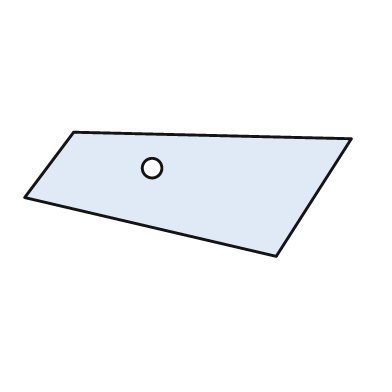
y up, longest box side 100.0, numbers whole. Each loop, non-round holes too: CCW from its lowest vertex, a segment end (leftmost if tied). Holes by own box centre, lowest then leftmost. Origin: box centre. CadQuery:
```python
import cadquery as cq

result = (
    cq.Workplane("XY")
    .moveTo(27.0, -19.0)
    .lineTo(50.0, 17.0)
    .lineTo(-35.0, 19.0)
    .lineTo(-50.0, -1.0)
    .close()
    .moveTo(-11.0, 8.0)
    .circle(3.0)
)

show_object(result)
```